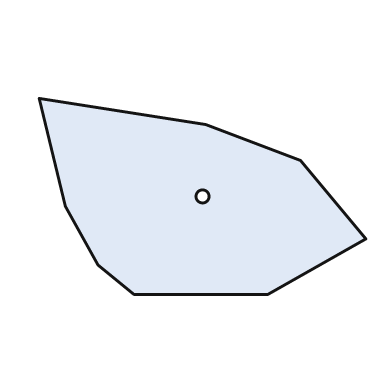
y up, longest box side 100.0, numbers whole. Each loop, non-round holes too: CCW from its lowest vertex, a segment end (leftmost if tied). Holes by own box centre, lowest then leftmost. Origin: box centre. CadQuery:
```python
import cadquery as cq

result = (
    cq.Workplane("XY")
    .moveTo(-21.0, -30.0)
    .lineTo(20.0, -30.0)
    .lineTo(50.0, -13.0)
    .lineTo(30.0, 11.0)
    .lineTo(1.0, 22.0)
    .lineTo(-50.0, 30.0)
    .lineTo(-42.0, -3.0)
    .lineTo(-32.0, -21.0)
    .close()
    .moveTo(0.0, 0.0)
    .circle(2.0)
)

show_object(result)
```